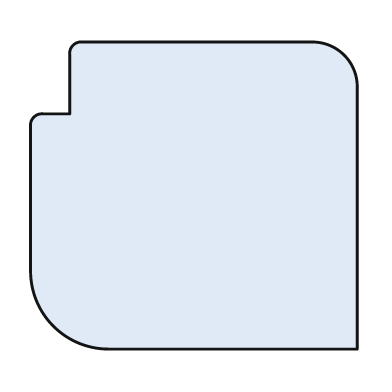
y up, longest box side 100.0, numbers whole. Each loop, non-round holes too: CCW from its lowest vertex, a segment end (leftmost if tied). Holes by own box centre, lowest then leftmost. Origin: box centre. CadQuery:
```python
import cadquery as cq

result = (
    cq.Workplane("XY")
    .moveTo(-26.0, -47.0)
    .lineTo(50.0, -47.0)
    .lineTo(50.0, 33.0)
    .threePointArc((46.0, 43.0), (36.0, 47.0))
    .lineTo(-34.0, 47.0)
    .threePointArc((-37.0, 46.0), (-38.0, 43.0))
    .lineTo(-38.0, 25.0)
    .lineTo(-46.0, 25.0)
    .threePointArc((-49.0, 24.0), (-50.0, 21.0))
    .lineTo(-50.0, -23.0)
    .threePointArc((-43.0, -40.0), (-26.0, -47.0))
    .close()
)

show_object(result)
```